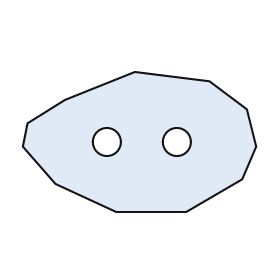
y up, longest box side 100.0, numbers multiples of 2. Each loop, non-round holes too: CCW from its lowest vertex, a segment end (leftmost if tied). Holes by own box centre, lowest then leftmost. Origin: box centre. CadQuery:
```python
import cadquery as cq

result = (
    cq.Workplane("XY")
    .moveTo(-10.0, -30.0)
    .lineTo(20.0, -30.0)
    .lineTo(44.0, -16.0)
    .lineTo(50.0, -2.0)
    .lineTo(46.0, 14.0)
    .lineTo(30.0, 26.0)
    .lineTo(-2.0, 30.0)
    .lineTo(-32.0, 18.0)
    .lineTo(-48.0, 8.0)
    .lineTo(-50.0, -2.0)
    .lineTo(-36.0, -18.0)
    .close()
    .moveTo(-14.0, 0.0)
    .circle(6.0)
    .moveTo(16.0, 0.0)
    .circle(6.0)
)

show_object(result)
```